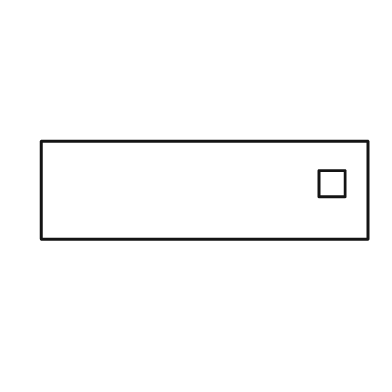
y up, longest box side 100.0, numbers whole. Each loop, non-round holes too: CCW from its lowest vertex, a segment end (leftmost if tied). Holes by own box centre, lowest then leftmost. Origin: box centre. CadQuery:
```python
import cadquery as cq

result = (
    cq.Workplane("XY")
    .moveTo(-50.0, -15.0)
    .lineTo(50.0, -15.0)
    .lineTo(50.0, 15.0)
    .lineTo(-50.0, 15.0)
    .close()
    .moveTo(35.0, -2.0)
    .lineTo(43.0, -2.0)
    .lineTo(43.0, 6.0)
    .lineTo(35.0, 6.0)
    .close()
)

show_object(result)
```